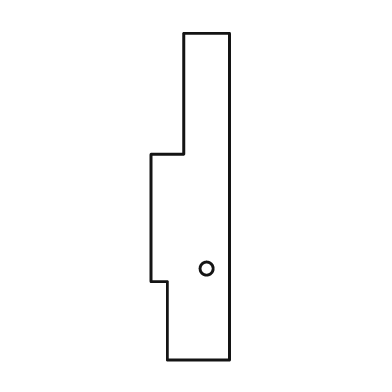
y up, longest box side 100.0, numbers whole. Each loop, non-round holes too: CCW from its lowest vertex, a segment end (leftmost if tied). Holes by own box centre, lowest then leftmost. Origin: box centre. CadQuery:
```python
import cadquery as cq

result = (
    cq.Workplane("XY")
    .moveTo(-7.0, -50.0)
    .lineTo(12.0, -50.0)
    .lineTo(12.0, 50.0)
    .lineTo(-2.0, 50.0)
    .lineTo(-2.0, 13.0)
    .lineTo(-12.0, 13.0)
    .lineTo(-12.0, -26.0)
    .lineTo(-7.0, -26.0)
    .close()
    .moveTo(5.0, -22.0)
    .circle(2.0)
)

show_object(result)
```